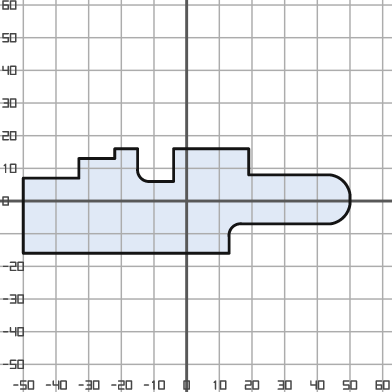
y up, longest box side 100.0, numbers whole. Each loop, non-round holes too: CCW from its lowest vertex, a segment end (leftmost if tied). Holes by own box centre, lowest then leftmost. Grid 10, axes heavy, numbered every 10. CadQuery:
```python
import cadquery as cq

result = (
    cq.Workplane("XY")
    .moveTo(-50.0, -16.0)
    .lineTo(13.0, -16.0)
    .lineTo(13.0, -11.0)
    .threePointArc((14.0, -8.0), (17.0, -7.0))
    .lineTo(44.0, -7.0)
    .threePointArc((48.0, -5.0), (50.0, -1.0))
    .lineTo(50.0, 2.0)
    .threePointArc((48.0, 6.0), (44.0, 8.0))
    .lineTo(19.0, 8.0)
    .lineTo(19.0, 16.0)
    .lineTo(-4.0, 16.0)
    .lineTo(-4.0, 6.0)
    .lineTo(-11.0, 6.0)
    .threePointArc((-14.0, 7.0), (-15.0, 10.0))
    .lineTo(-15.0, 16.0)
    .lineTo(-22.0, 16.0)
    .lineTo(-22.0, 13.0)
    .lineTo(-33.0, 13.0)
    .lineTo(-33.0, 7.0)
    .lineTo(-50.0, 7.0)
    .close()
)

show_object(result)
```